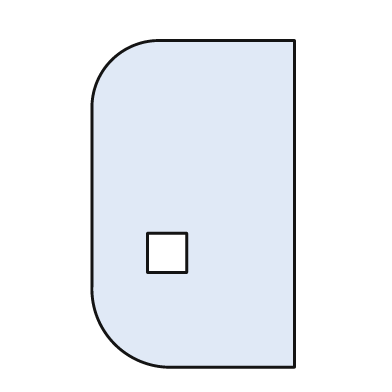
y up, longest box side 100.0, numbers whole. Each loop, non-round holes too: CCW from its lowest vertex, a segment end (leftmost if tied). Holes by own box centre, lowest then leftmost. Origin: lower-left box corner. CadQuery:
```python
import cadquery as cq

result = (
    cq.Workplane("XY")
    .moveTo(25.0, 0.0)
    .lineTo(62.0, 0.0)
    .lineTo(62.0, 100.0)
    .lineTo(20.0, 100.0)
    .threePointArc((6.0, 94.0), (0.0, 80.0))
    .lineTo(0.0, 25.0)
    .threePointArc((7.0, 7.0), (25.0, 0.0))
    .close()
    .moveTo(17.0, 29.0)
    .lineTo(29.0, 29.0)
    .lineTo(29.0, 41.0)
    .lineTo(17.0, 41.0)
    .close()
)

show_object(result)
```